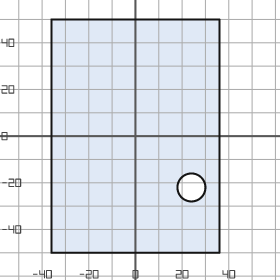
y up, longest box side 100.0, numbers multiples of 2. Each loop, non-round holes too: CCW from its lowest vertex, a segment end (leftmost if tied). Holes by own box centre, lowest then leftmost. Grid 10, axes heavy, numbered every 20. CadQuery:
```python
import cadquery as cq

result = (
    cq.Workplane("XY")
    .moveTo(-36.0, -50.0)
    .lineTo(36.0, -50.0)
    .lineTo(36.0, 50.0)
    .lineTo(-36.0, 50.0)
    .close()
    .moveTo(24.0, -22.0)
    .circle(6.0)
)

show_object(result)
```